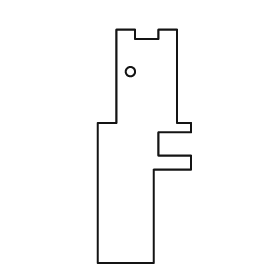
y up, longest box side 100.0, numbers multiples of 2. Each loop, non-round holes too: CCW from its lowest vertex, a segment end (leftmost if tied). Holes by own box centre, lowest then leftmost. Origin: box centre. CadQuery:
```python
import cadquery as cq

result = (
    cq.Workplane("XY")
    .moveTo(-20.0, -50.0)
    .lineTo(4.0, -50.0)
    .lineTo(4.0, -10.0)
    .lineTo(20.0, -10.0)
    .lineTo(20.0, -4.0)
    .lineTo(6.0, -4.0)
    .lineTo(6.0, 6.0)
    .lineTo(20.0, 6.0)
    .lineTo(20.0, 10.0)
    .lineTo(14.0, 10.0)
    .lineTo(14.0, 50.0)
    .lineTo(6.0, 50.0)
    .lineTo(6.0, 46.0)
    .lineTo(-4.0, 46.0)
    .lineTo(-4.0, 50.0)
    .lineTo(-12.0, 50.0)
    .lineTo(-12.0, 10.0)
    .lineTo(-20.0, 10.0)
    .close()
    .moveTo(-6.0, 32.0)
    .circle(2.0)
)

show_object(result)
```